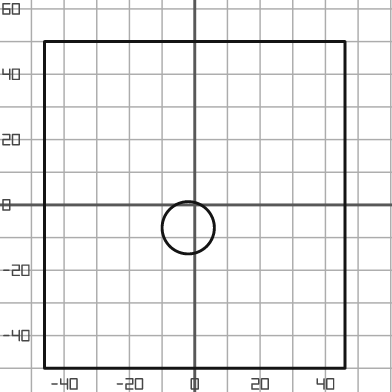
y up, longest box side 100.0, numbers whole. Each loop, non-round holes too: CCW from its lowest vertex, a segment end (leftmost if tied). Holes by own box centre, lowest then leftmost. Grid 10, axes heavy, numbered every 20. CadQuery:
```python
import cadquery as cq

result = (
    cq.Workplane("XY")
    .moveTo(-46.0, -50.0)
    .lineTo(46.0, -50.0)
    .lineTo(46.0, 50.0)
    .lineTo(-46.0, 50.0)
    .close()
    .moveTo(-2.0, -7.0)
    .circle(8.0)
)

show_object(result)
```